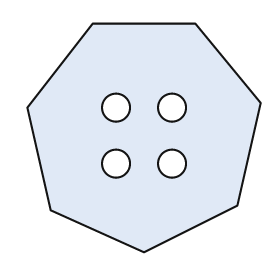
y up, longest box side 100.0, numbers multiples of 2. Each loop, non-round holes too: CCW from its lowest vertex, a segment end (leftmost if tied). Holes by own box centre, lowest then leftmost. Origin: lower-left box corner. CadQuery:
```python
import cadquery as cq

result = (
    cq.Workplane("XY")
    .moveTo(50.0, 0.0)
    .lineTo(90.0, 20.0)
    .lineTo(100.0, 64.0)
    .lineTo(72.0, 98.0)
    .lineTo(28.0, 98.0)
    .lineTo(0.0, 62.0)
    .lineTo(10.0, 18.0)
    .close()
    .moveTo(38.0, 38.0)
    .circle(6.0)
    .moveTo(62.0, 38.0)
    .circle(6.0)
    .moveTo(38.0, 62.0)
    .circle(6.0)
    .moveTo(62.0, 62.0)
    .circle(6.0)
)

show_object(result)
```